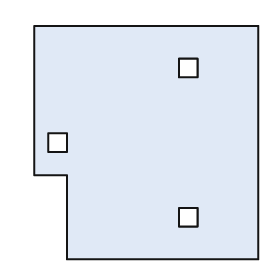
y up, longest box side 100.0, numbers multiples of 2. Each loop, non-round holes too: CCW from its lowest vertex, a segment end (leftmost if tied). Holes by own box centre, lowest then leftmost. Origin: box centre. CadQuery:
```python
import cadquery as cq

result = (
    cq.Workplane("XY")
    .moveTo(-34.0, -50.0)
    .lineTo(48.0, -50.0)
    .lineTo(48.0, 50.0)
    .lineTo(-48.0, 50.0)
    .lineTo(-48.0, -14.0)
    .lineTo(-34.0, -14.0)
    .close()
    .moveTo(14.0, -36.0)
    .lineTo(22.0, -36.0)
    .lineTo(22.0, -28.0)
    .lineTo(14.0, -28.0)
    .close()
    .moveTo(-42.0, -4.0)
    .lineTo(-34.0, -4.0)
    .lineTo(-34.0, 4.0)
    .lineTo(-42.0, 4.0)
    .close()
    .moveTo(14.0, 28.0)
    .lineTo(22.0, 28.0)
    .lineTo(22.0, 36.0)
    .lineTo(14.0, 36.0)
    .close()
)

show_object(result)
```